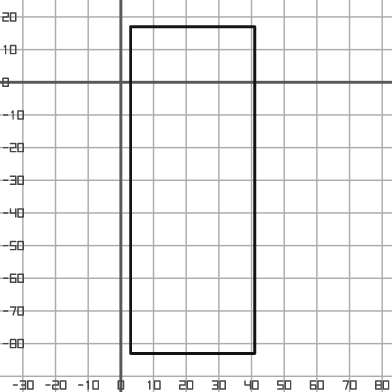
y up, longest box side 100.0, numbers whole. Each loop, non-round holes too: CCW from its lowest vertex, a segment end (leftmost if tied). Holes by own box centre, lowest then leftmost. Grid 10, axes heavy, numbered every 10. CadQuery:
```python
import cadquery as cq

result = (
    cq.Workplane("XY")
    .moveTo(3.0, -83.0)
    .lineTo(41.0, -83.0)
    .lineTo(41.0, 17.0)
    .lineTo(3.0, 17.0)
    .close()
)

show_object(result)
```